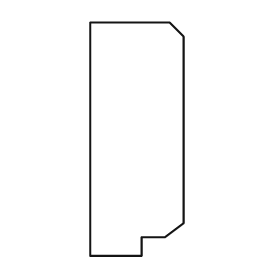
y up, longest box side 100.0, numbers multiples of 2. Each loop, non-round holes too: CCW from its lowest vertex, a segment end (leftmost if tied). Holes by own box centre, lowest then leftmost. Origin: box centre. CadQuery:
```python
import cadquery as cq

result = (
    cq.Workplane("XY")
    .moveTo(-20.0, -50.0)
    .lineTo(2.0, -50.0)
    .lineTo(2.0, -42.0)
    .lineTo(12.0, -42.0)
    .lineTo(20.0, -36.0)
    .lineTo(20.0, 44.0)
    .lineTo(14.0, 50.0)
    .lineTo(-20.0, 50.0)
    .close()
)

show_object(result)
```